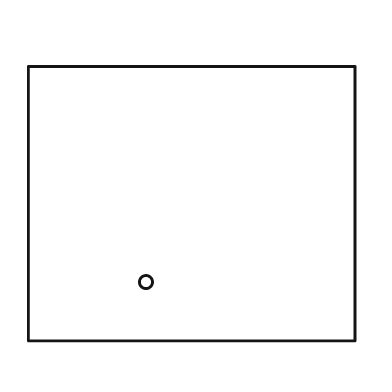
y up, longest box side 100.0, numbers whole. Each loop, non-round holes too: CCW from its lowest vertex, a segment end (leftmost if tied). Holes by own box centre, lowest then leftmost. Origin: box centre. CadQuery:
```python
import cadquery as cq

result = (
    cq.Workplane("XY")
    .moveTo(-50.0, -42.0)
    .lineTo(50.0, -42.0)
    .lineTo(50.0, 42.0)
    .lineTo(-50.0, 42.0)
    .close()
    .moveTo(-14.0, -24.0)
    .circle(2.0)
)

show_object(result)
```